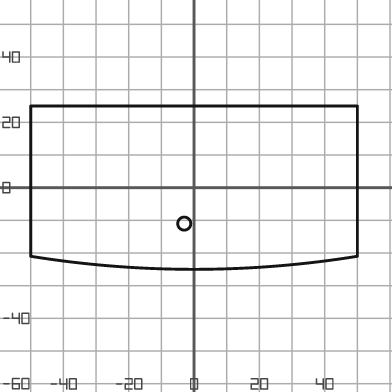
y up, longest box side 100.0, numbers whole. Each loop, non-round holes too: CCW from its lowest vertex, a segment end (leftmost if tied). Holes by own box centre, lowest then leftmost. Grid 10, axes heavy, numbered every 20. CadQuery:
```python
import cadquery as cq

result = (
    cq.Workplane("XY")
    .moveTo(-50.0, -21.0)
    .threePointArc((0.0, -25.0), (50.0, -21.0))
    .lineTo(50.0, 25.0)
    .lineTo(-50.0, 25.0)
    .close()
    .moveTo(-3.0, -11.0)
    .circle(2.0)
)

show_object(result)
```